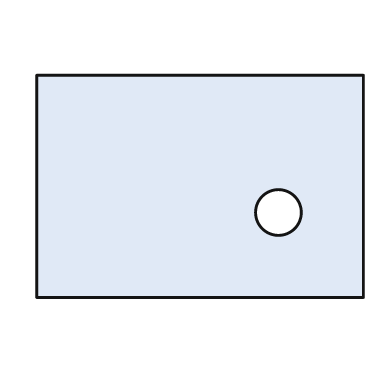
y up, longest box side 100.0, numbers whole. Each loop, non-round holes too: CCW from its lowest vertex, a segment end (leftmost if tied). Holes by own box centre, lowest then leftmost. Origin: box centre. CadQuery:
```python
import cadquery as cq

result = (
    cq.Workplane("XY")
    .moveTo(-50.0, -34.0)
    .lineTo(50.0, -34.0)
    .lineTo(50.0, 34.0)
    .lineTo(-50.0, 34.0)
    .close()
    .moveTo(24.0, -8.0)
    .circle(7.0)
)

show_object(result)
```